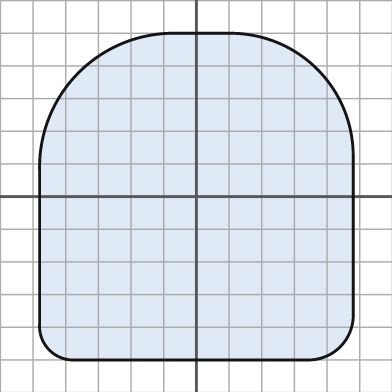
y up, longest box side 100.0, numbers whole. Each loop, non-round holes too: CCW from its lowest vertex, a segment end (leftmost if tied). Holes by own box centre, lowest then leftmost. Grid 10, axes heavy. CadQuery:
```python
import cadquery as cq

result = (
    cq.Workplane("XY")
    .moveTo(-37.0, -50.0)
    .lineTo(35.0, -50.0)
    .threePointArc((44.0, -46.0), (48.0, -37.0))
    .lineTo(48.0, 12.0)
    .threePointArc((37.0, 39.0), (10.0, 50.0))
    .lineTo(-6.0, 50.0)
    .threePointArc((-36.0, 38.0), (-48.0, 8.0))
    .lineTo(-48.0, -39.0)
    .threePointArc((-45.0, -47.0), (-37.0, -50.0))
    .close()
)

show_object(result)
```